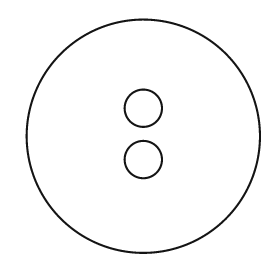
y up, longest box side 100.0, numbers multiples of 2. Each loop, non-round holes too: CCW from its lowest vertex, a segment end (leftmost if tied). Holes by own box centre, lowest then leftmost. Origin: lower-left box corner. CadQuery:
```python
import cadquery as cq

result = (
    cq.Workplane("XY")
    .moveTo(50.0, 50.0)
    .circle(50.0)
    .moveTo(50.0, 40.0)
    .circle(8.0)
    .moveTo(50.0, 62.0)
    .circle(8.0)
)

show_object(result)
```